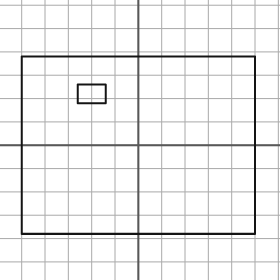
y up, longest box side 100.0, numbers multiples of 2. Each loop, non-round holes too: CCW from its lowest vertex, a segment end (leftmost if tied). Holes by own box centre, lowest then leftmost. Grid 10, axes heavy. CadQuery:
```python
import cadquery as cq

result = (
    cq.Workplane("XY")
    .moveTo(-50.0, -38.0)
    .lineTo(50.0, -38.0)
    .lineTo(50.0, 38.0)
    .lineTo(-50.0, 38.0)
    .close()
    .moveTo(-26.0, 18.0)
    .lineTo(-14.0, 18.0)
    .lineTo(-14.0, 26.0)
    .lineTo(-26.0, 26.0)
    .close()
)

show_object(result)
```